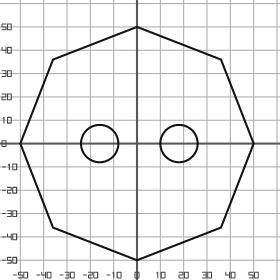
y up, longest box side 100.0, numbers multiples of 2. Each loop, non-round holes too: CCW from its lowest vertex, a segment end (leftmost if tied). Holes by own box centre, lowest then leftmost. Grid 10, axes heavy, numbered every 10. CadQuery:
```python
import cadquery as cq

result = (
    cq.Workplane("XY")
    .moveTo(0.0, -50.0)
    .lineTo(36.0, -36.0)
    .lineTo(50.0, 0.0)
    .lineTo(36.0, 36.0)
    .lineTo(0.0, 50.0)
    .lineTo(-36.0, 36.0)
    .lineTo(-50.0, 0.0)
    .lineTo(-36.0, -36.0)
    .close()
    .moveTo(-16.0, 0.0)
    .circle(8.0)
    .moveTo(18.0, 0.0)
    .circle(8.0)
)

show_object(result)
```